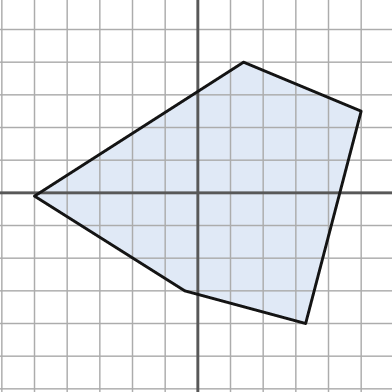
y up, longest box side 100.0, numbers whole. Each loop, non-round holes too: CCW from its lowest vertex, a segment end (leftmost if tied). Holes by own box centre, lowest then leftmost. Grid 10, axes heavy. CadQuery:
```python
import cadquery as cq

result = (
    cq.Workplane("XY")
    .moveTo(33.0, -40.0)
    .lineTo(50.0, 25.0)
    .lineTo(14.0, 40.0)
    .lineTo(-50.0, -1.0)
    .lineTo(-4.0, -30.0)
    .close()
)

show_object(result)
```